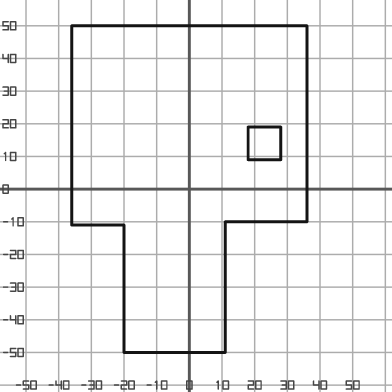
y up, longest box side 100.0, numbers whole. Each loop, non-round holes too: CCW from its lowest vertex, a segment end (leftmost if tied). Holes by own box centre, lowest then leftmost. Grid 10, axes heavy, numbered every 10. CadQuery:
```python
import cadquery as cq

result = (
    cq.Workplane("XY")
    .moveTo(-20.0, -50.0)
    .lineTo(11.0, -50.0)
    .lineTo(11.0, -10.0)
    .lineTo(36.0, -10.0)
    .lineTo(36.0, 50.0)
    .lineTo(-36.0, 50.0)
    .lineTo(-36.0, -11.0)
    .lineTo(-20.0, -11.0)
    .close()
    .moveTo(18.0, 9.0)
    .lineTo(28.0, 9.0)
    .lineTo(28.0, 19.0)
    .lineTo(18.0, 19.0)
    .close()
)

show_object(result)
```